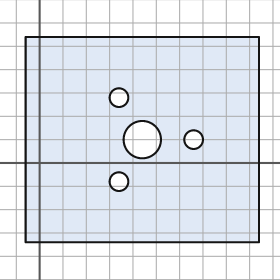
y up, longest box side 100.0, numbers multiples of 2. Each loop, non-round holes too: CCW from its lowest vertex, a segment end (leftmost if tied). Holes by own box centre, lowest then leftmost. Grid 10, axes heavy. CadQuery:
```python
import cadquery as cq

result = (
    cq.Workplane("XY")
    .moveTo(-6.0, -34.0)
    .lineTo(94.0, -34.0)
    .lineTo(94.0, 54.0)
    .lineTo(-6.0, 54.0)
    .close()
    .moveTo(34.0, -8.0)
    .circle(4.0)
    .moveTo(44.0, 10.0)
    .circle(8.0)
    .moveTo(66.0, 10.0)
    .circle(4.0)
    .moveTo(34.0, 28.0)
    .circle(4.0)
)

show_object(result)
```